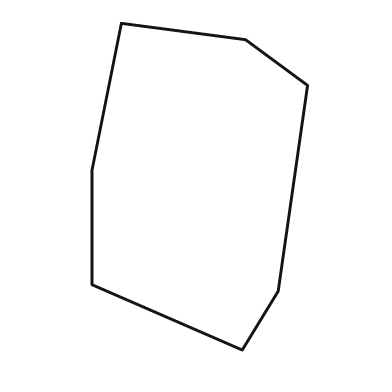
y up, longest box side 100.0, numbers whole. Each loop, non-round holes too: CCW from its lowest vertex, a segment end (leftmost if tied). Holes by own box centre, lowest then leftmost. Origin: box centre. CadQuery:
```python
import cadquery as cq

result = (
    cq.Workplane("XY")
    .moveTo(13.0, -50.0)
    .lineTo(24.0, -32.0)
    .lineTo(33.0, 31.0)
    .lineTo(14.0, 45.0)
    .lineTo(-24.0, 50.0)
    .lineTo(-33.0, 5.0)
    .lineTo(-33.0, -30.0)
    .close()
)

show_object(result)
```